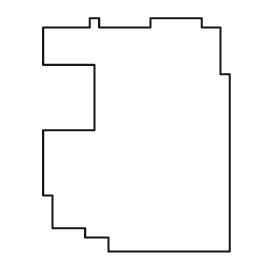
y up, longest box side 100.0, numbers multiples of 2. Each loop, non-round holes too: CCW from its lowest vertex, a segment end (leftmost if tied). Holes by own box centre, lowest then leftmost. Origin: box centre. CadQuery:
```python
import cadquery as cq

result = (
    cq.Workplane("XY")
    .moveTo(-12.0, -50.0)
    .lineTo(40.0, -50.0)
    .lineTo(40.0, 26.0)
    .lineTo(36.0, 26.0)
    .lineTo(36.0, 46.0)
    .lineTo(28.0, 46.0)
    .lineTo(28.0, 50.0)
    .lineTo(6.0, 50.0)
    .lineTo(6.0, 46.0)
    .lineTo(-16.0, 46.0)
    .lineTo(-16.0, 50.0)
    .lineTo(-20.0, 50.0)
    .lineTo(-20.0, 46.0)
    .lineTo(-40.0, 46.0)
    .lineTo(-40.0, 30.0)
    .lineTo(-18.0, 30.0)
    .lineTo(-18.0, 2.0)
    .lineTo(-40.0, 2.0)
    .lineTo(-40.0, -26.0)
    .lineTo(-36.0, -26.0)
    .lineTo(-36.0, -40.0)
    .lineTo(-22.0, -40.0)
    .lineTo(-22.0, -44.0)
    .lineTo(-12.0, -44.0)
    .close()
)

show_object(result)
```